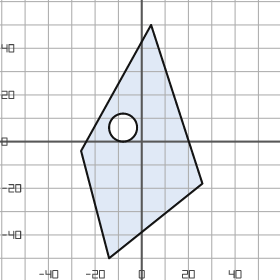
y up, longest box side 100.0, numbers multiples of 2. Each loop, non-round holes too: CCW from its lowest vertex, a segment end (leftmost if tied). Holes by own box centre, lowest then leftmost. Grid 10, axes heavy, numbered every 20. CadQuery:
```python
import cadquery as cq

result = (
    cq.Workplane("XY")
    .moveTo(-14.0, -50.0)
    .lineTo(26.0, -18.0)
    .lineTo(4.0, 50.0)
    .lineTo(-26.0, -4.0)
    .close()
    .moveTo(-8.0, 6.0)
    .circle(6.0)
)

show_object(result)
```